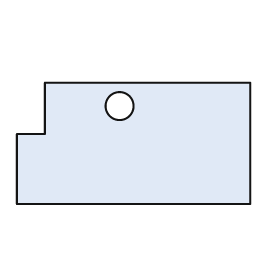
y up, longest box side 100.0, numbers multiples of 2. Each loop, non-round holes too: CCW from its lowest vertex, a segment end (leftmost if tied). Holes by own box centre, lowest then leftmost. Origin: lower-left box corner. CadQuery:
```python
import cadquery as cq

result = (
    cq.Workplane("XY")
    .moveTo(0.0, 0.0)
    .lineTo(100.0, 0.0)
    .lineTo(100.0, 52.0)
    .lineTo(12.0, 52.0)
    .lineTo(12.0, 30.0)
    .lineTo(0.0, 30.0)
    .close()
    .moveTo(44.0, 42.0)
    .circle(6.0)
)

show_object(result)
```